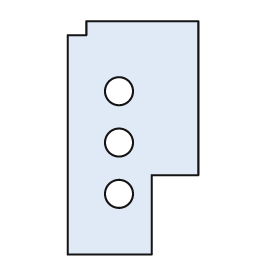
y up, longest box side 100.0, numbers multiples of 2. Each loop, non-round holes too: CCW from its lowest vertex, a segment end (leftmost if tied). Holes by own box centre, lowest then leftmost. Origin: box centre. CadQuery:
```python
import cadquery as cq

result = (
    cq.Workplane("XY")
    .moveTo(-28.0, -50.0)
    .lineTo(8.0, -50.0)
    .lineTo(8.0, -16.0)
    .lineTo(28.0, -16.0)
    .lineTo(28.0, 50.0)
    .lineTo(-20.0, 50.0)
    .lineTo(-20.0, 44.0)
    .lineTo(-28.0, 44.0)
    .close()
    .moveTo(-6.0, -24.0)
    .circle(6.0)
    .moveTo(-6.0, -2.0)
    .circle(6.0)
    .moveTo(-6.0, 20.0)
    .circle(6.0)
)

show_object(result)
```